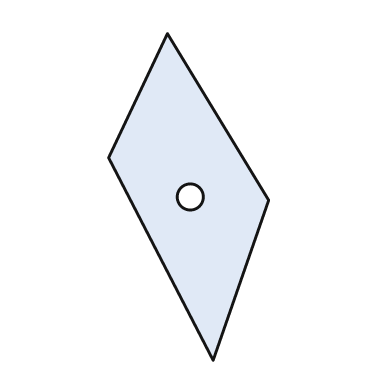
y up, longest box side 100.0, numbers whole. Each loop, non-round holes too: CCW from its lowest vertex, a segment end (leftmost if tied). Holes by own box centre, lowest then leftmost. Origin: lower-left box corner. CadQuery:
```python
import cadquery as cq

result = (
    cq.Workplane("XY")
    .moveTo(32.0, 0.0)
    .lineTo(49.0, 49.0)
    .lineTo(18.0, 100.0)
    .lineTo(0.0, 62.0)
    .close()
    .moveTo(25.0, 50.0)
    .circle(4.0)
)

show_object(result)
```